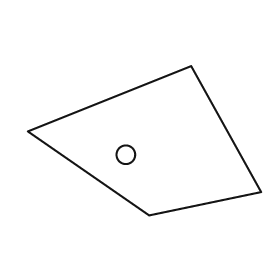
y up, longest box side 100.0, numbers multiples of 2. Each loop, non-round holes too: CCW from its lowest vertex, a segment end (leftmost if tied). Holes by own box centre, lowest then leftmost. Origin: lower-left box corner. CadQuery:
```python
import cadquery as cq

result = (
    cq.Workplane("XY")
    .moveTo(52.0, 0.0)
    .lineTo(100.0, 10.0)
    .lineTo(70.0, 64.0)
    .lineTo(0.0, 36.0)
    .close()
    .moveTo(42.0, 26.0)
    .circle(4.0)
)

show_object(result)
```